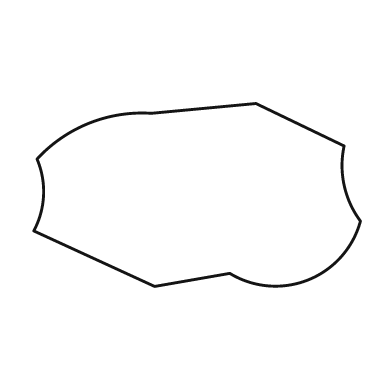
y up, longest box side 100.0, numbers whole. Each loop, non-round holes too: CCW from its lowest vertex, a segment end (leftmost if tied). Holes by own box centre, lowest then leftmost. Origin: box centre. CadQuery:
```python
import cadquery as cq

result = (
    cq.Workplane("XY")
    .moveTo(-13.0, -28.0)
    .lineTo(10.0, -24.0)
    .threePointArc((34.0, -26.0), (50.0, -8.0))
    .threePointArc((45.0, 3.0), (45.0, 15.0))
    .lineTo(18.0, 28.0)
    .lineTo(-14.0, 25.0)
    .threePointArc((-33.0, 22.0), (-49.0, 11.0))
    .threePointArc((-47.0, 0.0), (-50.0, -11.0))
    .close()
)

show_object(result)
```